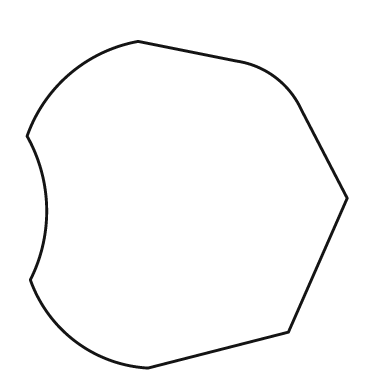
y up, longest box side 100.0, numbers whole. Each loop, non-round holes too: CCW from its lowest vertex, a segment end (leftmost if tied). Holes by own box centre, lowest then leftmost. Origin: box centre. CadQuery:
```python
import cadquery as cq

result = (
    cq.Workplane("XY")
    .moveTo(-12.0, -50.0)
    .lineTo(31.0, -39.0)
    .lineTo(49.0, 2.0)
    .lineTo(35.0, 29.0)
    .threePointArc((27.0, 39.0), (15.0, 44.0))
    .lineTo(-15.0, 50.0)
    .threePointArc((-36.0, 40.0), (-49.0, 21.0))
    .threePointArc((-43.0, -1.0), (-48.0, -23.0))
    .threePointArc((-34.0, -42.0), (-12.0, -50.0))
    .close()
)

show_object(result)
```